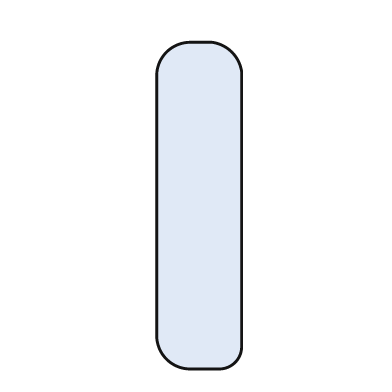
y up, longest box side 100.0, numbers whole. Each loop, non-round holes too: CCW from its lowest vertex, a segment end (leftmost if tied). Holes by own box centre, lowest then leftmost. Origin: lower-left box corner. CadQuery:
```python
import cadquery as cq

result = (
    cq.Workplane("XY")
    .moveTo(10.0, 0.0)
    .lineTo(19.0, 0.0)
    .threePointArc((24.0, 2.0), (26.0, 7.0))
    .lineTo(26.0, 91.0)
    .threePointArc((23.0, 97.0), (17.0, 100.0))
    .lineTo(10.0, 100.0)
    .threePointArc((3.0, 97.0), (0.0, 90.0))
    .lineTo(0.0, 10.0)
    .threePointArc((3.0, 3.0), (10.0, 0.0))
    .close()
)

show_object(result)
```